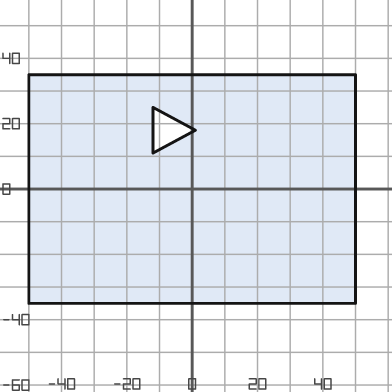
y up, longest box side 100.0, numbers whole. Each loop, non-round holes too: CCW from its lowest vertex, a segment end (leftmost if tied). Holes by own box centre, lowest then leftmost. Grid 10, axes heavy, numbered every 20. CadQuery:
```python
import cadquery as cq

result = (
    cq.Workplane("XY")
    .moveTo(-50.0, -35.0)
    .lineTo(50.0, -35.0)
    .lineTo(50.0, 35.0)
    .lineTo(-50.0, 35.0)
    .close()
    .moveTo(-12.0, 11.0)
    .lineTo(1.0, 18.0)
    .lineTo(-12.0, 25.0)
    .close()
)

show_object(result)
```